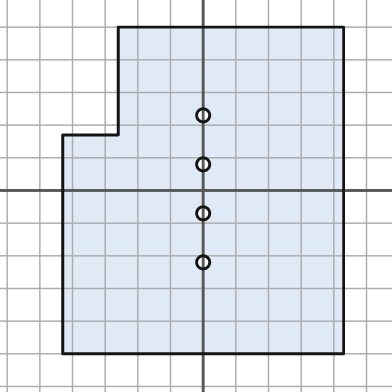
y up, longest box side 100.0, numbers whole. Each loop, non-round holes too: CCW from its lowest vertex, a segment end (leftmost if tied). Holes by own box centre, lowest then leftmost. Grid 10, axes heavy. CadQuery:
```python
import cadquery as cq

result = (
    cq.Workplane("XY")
    .moveTo(-43.0, -50.0)
    .lineTo(43.0, -50.0)
    .lineTo(43.0, 50.0)
    .lineTo(-26.0, 50.0)
    .lineTo(-26.0, 17.0)
    .lineTo(-43.0, 17.0)
    .close()
    .moveTo(0.0, -22.0)
    .circle(2.0)
    .moveTo(0.0, -7.0)
    .circle(2.0)
    .moveTo(0.0, 8.0)
    .circle(2.0)
    .moveTo(0.0, 23.0)
    .circle(2.0)
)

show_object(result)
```